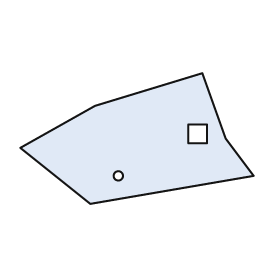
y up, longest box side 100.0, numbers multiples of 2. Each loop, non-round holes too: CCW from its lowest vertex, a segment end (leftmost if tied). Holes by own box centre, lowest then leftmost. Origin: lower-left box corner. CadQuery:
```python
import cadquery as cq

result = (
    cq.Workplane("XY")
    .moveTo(30.0, 0.0)
    .lineTo(100.0, 12.0)
    .lineTo(88.0, 28.0)
    .lineTo(78.0, 56.0)
    .lineTo(32.0, 42.0)
    .lineTo(0.0, 24.0)
    .close()
    .moveTo(42.0, 12.0)
    .circle(2.0)
    .moveTo(72.0, 26.0)
    .lineTo(80.0, 26.0)
    .lineTo(80.0, 34.0)
    .lineTo(72.0, 34.0)
    .close()
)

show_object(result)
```